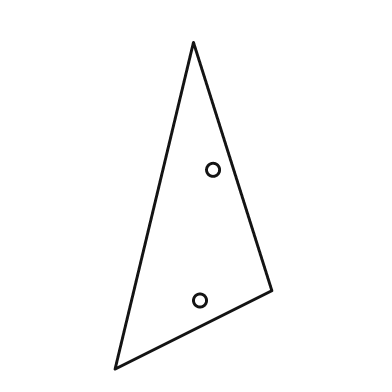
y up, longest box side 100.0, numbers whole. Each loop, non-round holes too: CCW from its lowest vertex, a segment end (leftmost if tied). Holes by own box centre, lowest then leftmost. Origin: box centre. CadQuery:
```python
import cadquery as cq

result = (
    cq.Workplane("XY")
    .moveTo(-24.0, -50.0)
    .lineTo(24.0, -26.0)
    .lineTo(0.0, 50.0)
    .close()
    .moveTo(2.0, -29.0)
    .circle(2.0)
    .moveTo(6.0, 11.0)
    .circle(2.0)
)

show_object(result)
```